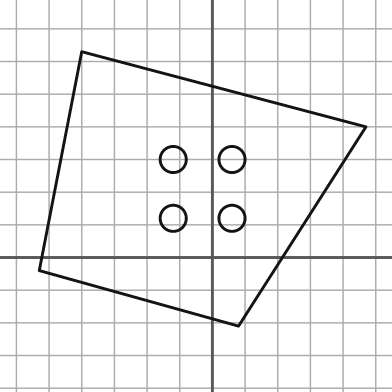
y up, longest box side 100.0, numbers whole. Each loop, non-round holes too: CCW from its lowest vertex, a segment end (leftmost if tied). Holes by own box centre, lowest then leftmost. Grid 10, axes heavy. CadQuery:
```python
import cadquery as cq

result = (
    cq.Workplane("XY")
    .moveTo(8.0, -21.0)
    .lineTo(47.0, 40.0)
    .lineTo(-40.0, 63.0)
    .lineTo(-53.0, -4.0)
    .close()
    .moveTo(-12.0, 12.0)
    .circle(4.0)
    .moveTo(6.0, 12.0)
    .circle(4.0)
    .moveTo(-12.0, 30.0)
    .circle(4.0)
    .moveTo(6.0, 30.0)
    .circle(4.0)
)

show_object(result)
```